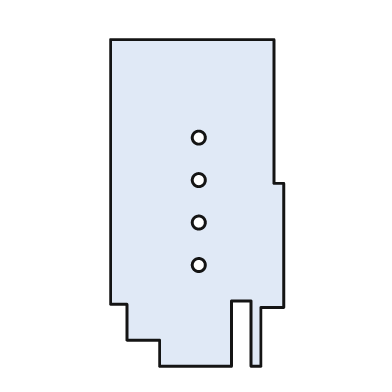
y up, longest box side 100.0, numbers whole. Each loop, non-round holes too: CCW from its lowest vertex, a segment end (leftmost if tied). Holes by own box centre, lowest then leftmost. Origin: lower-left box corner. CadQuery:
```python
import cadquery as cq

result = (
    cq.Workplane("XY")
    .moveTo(15.0, 0.0)
    .lineTo(37.0, 0.0)
    .lineTo(37.0, 20.0)
    .lineTo(43.0, 20.0)
    .lineTo(43.0, 0.0)
    .lineTo(46.0, 0.0)
    .lineTo(46.0, 18.0)
    .lineTo(53.0, 18.0)
    .lineTo(53.0, 56.0)
    .lineTo(50.0, 56.0)
    .lineTo(50.0, 100.0)
    .lineTo(0.0, 100.0)
    .lineTo(0.0, 19.0)
    .lineTo(5.0, 19.0)
    .lineTo(5.0, 8.0)
    .lineTo(15.0, 8.0)
    .close()
    .moveTo(27.0, 31.0)
    .circle(2.0)
    .moveTo(27.0, 44.0)
    .circle(2.0)
    .moveTo(27.0, 57.0)
    .circle(2.0)
    .moveTo(27.0, 70.0)
    .circle(2.0)
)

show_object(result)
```